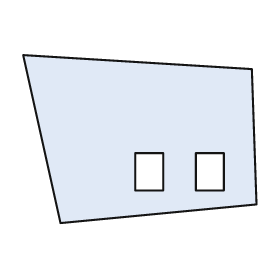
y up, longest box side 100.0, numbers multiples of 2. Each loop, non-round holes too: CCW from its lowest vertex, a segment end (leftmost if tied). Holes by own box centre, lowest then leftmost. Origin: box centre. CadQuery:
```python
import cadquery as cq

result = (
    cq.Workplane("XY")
    .moveTo(-34.0, -36.0)
    .lineTo(50.0, -28.0)
    .lineTo(48.0, 30.0)
    .lineTo(-50.0, 36.0)
    .close()
    .moveTo(-2.0, -22.0)
    .lineTo(10.0, -22.0)
    .lineTo(10.0, -6.0)
    .lineTo(-2.0, -6.0)
    .close()
    .moveTo(24.0, -22.0)
    .lineTo(36.0, -22.0)
    .lineTo(36.0, -6.0)
    .lineTo(24.0, -6.0)
    .close()
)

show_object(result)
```